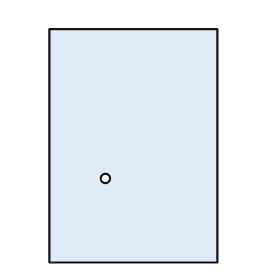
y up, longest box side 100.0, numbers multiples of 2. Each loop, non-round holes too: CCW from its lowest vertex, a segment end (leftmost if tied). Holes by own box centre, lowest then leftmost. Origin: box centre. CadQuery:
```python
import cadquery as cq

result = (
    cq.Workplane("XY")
    .moveTo(-36.0, -50.0)
    .lineTo(36.0, -50.0)
    .lineTo(36.0, 50.0)
    .lineTo(-36.0, 50.0)
    .close()
    .moveTo(-12.0, -14.0)
    .circle(2.0)
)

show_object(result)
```